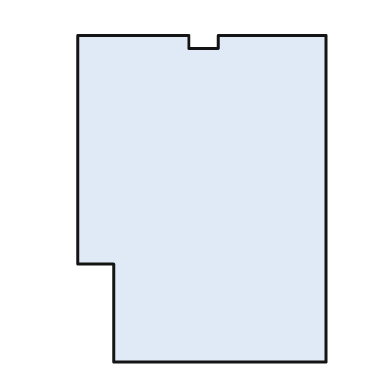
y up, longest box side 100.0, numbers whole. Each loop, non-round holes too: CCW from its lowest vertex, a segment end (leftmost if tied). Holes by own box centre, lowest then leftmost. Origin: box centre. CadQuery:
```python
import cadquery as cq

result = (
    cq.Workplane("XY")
    .moveTo(-27.0, -50.0)
    .lineTo(38.0, -50.0)
    .lineTo(38.0, 50.0)
    .lineTo(5.0, 50.0)
    .lineTo(5.0, 46.0)
    .lineTo(-4.0, 46.0)
    .lineTo(-4.0, 50.0)
    .lineTo(-38.0, 50.0)
    .lineTo(-38.0, -20.0)
    .lineTo(-27.0, -20.0)
    .close()
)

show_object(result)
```